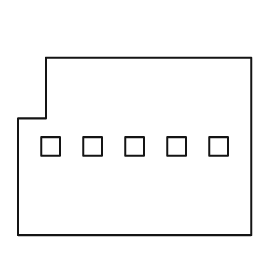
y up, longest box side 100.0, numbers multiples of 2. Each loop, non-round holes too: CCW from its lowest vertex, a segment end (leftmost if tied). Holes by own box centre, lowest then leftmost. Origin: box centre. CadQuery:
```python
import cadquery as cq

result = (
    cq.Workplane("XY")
    .moveTo(-50.0, -38.0)
    .lineTo(50.0, -38.0)
    .lineTo(50.0, 38.0)
    .lineTo(-38.0, 38.0)
    .lineTo(-38.0, 12.0)
    .lineTo(-50.0, 12.0)
    .close()
    .moveTo(-40.0, -4.0)
    .lineTo(-32.0, -4.0)
    .lineTo(-32.0, 4.0)
    .lineTo(-40.0, 4.0)
    .close()
    .moveTo(-22.0, -4.0)
    .lineTo(-14.0, -4.0)
    .lineTo(-14.0, 4.0)
    .lineTo(-22.0, 4.0)
    .close()
    .moveTo(-4.0, -4.0)
    .lineTo(4.0, -4.0)
    .lineTo(4.0, 4.0)
    .lineTo(-4.0, 4.0)
    .close()
    .moveTo(14.0, -4.0)
    .lineTo(22.0, -4.0)
    .lineTo(22.0, 4.0)
    .lineTo(14.0, 4.0)
    .close()
    .moveTo(32.0, -4.0)
    .lineTo(40.0, -4.0)
    .lineTo(40.0, 4.0)
    .lineTo(32.0, 4.0)
    .close()
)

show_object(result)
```